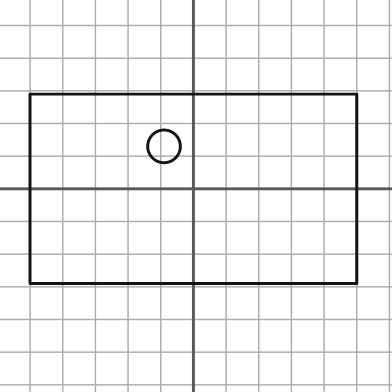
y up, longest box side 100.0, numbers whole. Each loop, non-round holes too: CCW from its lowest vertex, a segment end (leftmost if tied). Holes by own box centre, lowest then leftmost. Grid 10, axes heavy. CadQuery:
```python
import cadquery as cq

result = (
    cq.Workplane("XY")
    .moveTo(-50.0, -29.0)
    .lineTo(50.0, -29.0)
    .lineTo(50.0, 29.0)
    .lineTo(-50.0, 29.0)
    .close()
    .moveTo(-9.0, 13.0)
    .circle(5.0)
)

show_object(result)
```